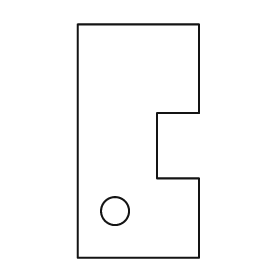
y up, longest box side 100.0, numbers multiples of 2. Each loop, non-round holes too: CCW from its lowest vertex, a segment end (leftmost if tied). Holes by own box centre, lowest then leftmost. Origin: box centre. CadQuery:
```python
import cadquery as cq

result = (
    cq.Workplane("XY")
    .moveTo(-26.0, -50.0)
    .lineTo(26.0, -50.0)
    .lineTo(26.0, -16.0)
    .lineTo(8.0, -16.0)
    .lineTo(8.0, 12.0)
    .lineTo(26.0, 12.0)
    .lineTo(26.0, 50.0)
    .lineTo(-26.0, 50.0)
    .close()
    .moveTo(-10.0, -30.0)
    .circle(6.0)
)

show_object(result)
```